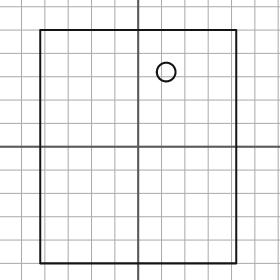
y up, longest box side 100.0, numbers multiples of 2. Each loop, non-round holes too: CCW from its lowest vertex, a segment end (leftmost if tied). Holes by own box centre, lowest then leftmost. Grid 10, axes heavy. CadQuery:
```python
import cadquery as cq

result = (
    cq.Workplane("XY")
    .moveTo(-42.0, -50.0)
    .lineTo(42.0, -50.0)
    .lineTo(42.0, 50.0)
    .lineTo(-42.0, 50.0)
    .close()
    .moveTo(12.0, 32.0)
    .circle(4.0)
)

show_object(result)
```